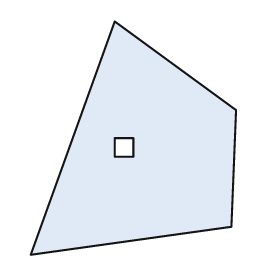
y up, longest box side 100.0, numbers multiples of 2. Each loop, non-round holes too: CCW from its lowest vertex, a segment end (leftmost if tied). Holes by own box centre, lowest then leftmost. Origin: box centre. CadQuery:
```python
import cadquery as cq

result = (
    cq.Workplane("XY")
    .moveTo(-44.0, -50.0)
    .lineTo(42.0, -38.0)
    .lineTo(44.0, 12.0)
    .lineTo(-8.0, 50.0)
    .close()
    .moveTo(-8.0, -8.0)
    .lineTo(0.0, -8.0)
    .lineTo(0.0, 0.0)
    .lineTo(-8.0, 0.0)
    .close()
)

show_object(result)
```